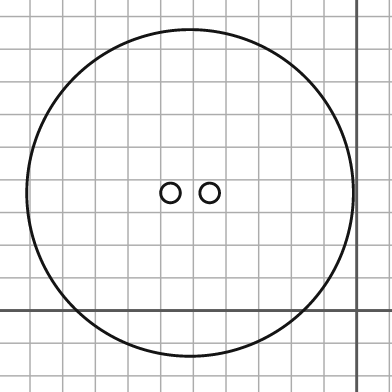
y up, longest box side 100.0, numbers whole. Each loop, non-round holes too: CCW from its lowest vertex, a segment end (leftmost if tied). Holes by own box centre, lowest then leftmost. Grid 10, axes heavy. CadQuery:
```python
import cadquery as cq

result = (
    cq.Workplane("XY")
    .moveTo(-51.0, 36.0)
    .circle(50.0)
    .moveTo(-57.0, 36.0)
    .circle(3.0)
    .moveTo(-45.0, 36.0)
    .circle(3.0)
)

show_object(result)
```